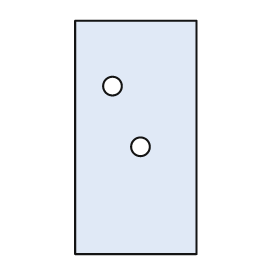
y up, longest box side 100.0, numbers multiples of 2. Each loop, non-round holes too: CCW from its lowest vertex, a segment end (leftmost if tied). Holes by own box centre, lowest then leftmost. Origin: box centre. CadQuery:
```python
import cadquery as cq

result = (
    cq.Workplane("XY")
    .moveTo(-26.0, -50.0)
    .lineTo(26.0, -50.0)
    .lineTo(26.0, 50.0)
    .lineTo(-26.0, 50.0)
    .close()
    .moveTo(2.0, -4.0)
    .circle(4.0)
    .moveTo(-10.0, 22.0)
    .circle(4.0)
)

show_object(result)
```